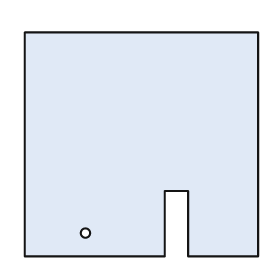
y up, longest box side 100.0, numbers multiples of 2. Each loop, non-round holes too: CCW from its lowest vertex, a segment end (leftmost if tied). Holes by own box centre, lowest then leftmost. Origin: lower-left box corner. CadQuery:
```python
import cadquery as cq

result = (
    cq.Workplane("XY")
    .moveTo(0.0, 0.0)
    .lineTo(60.0, 0.0)
    .lineTo(60.0, 28.0)
    .lineTo(70.0, 28.0)
    .lineTo(70.0, 0.0)
    .lineTo(100.0, 0.0)
    .lineTo(100.0, 96.0)
    .lineTo(0.0, 96.0)
    .close()
    .moveTo(26.0, 10.0)
    .circle(2.0)
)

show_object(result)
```